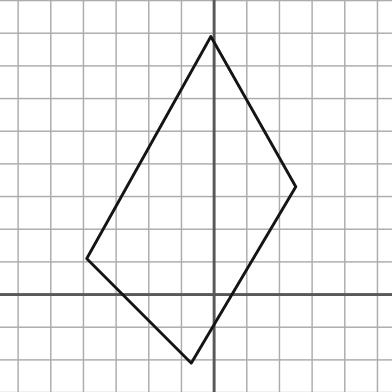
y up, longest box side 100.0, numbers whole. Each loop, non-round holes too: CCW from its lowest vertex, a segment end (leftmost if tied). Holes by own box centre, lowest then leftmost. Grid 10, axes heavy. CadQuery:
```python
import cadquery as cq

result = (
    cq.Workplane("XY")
    .moveTo(-7.0, -21.0)
    .lineTo(25.0, 33.0)
    .lineTo(-1.0, 79.0)
    .lineTo(-39.0, 11.0)
    .close()
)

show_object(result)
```